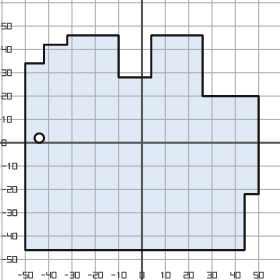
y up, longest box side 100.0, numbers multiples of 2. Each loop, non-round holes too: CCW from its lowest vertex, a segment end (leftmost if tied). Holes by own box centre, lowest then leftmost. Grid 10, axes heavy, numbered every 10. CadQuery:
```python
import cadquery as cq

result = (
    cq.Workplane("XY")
    .moveTo(-50.0, -46.0)
    .lineTo(44.0, -46.0)
    .lineTo(44.0, -22.0)
    .lineTo(50.0, -22.0)
    .lineTo(50.0, 20.0)
    .lineTo(26.0, 20.0)
    .lineTo(26.0, 46.0)
    .lineTo(4.0, 46.0)
    .lineTo(4.0, 28.0)
    .lineTo(-10.0, 28.0)
    .lineTo(-10.0, 46.0)
    .lineTo(-32.0, 46.0)
    .lineTo(-32.0, 42.0)
    .lineTo(-42.0, 42.0)
    .lineTo(-42.0, 34.0)
    .lineTo(-50.0, 34.0)
    .close()
    .moveTo(-44.0, 2.0)
    .circle(2.0)
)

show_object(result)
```